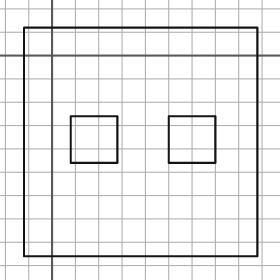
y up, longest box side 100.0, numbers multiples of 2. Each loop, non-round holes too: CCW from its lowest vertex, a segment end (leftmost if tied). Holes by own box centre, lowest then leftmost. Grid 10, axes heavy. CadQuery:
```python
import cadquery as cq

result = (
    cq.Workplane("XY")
    .moveTo(-12.0, -86.0)
    .lineTo(88.0, -86.0)
    .lineTo(88.0, 12.0)
    .lineTo(-12.0, 12.0)
    .close()
    .moveTo(8.0, -46.0)
    .lineTo(28.0, -46.0)
    .lineTo(28.0, -26.0)
    .lineTo(8.0, -26.0)
    .close()
    .moveTo(50.0, -46.0)
    .lineTo(70.0, -46.0)
    .lineTo(70.0, -26.0)
    .lineTo(50.0, -26.0)
    .close()
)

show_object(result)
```